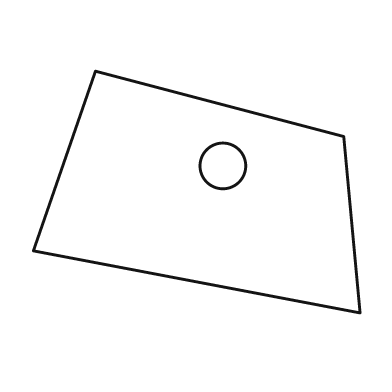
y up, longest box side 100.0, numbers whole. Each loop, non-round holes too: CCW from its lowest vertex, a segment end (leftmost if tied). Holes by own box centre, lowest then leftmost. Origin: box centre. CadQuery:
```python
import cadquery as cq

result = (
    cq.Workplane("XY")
    .moveTo(50.0, -37.0)
    .lineTo(45.0, 17.0)
    .lineTo(-31.0, 37.0)
    .lineTo(-50.0, -18.0)
    .close()
    .moveTo(8.0, 8.0)
    .circle(7.0)
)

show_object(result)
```